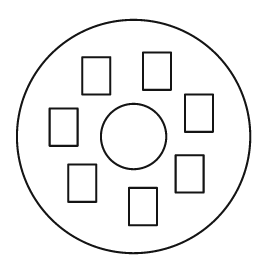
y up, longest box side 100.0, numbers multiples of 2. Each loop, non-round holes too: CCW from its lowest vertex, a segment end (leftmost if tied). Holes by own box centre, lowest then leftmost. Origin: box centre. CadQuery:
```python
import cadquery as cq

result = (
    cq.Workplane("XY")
    .moveTo(0.0, 0.0)
    .circle(50.0)
    .moveTo(-2.0, -38.0)
    .lineTo(10.0, -38.0)
    .lineTo(10.0, -22.0)
    .lineTo(-2.0, -22.0)
    .close()
    .moveTo(-28.0, -28.0)
    .lineTo(-16.0, -28.0)
    .lineTo(-16.0, -12.0)
    .lineTo(-28.0, -12.0)
    .close()
    .moveTo(18.0, -24.0)
    .lineTo(30.0, -24.0)
    .lineTo(30.0, -8.0)
    .lineTo(18.0, -8.0)
    .close()
    .moveTo(0.0, 0.0)
    .circle(14.0)
    .moveTo(-36.0, -4.0)
    .lineTo(-24.0, -4.0)
    .lineTo(-24.0, 12.0)
    .lineTo(-36.0, 12.0)
    .close()
    .moveTo(22.0, 2.0)
    .lineTo(34.0, 2.0)
    .lineTo(34.0, 18.0)
    .lineTo(22.0, 18.0)
    .close()
    .moveTo(-22.0, 18.0)
    .lineTo(-10.0, 18.0)
    .lineTo(-10.0, 34.0)
    .lineTo(-22.0, 34.0)
    .close()
    .moveTo(4.0, 20.0)
    .lineTo(16.0, 20.0)
    .lineTo(16.0, 36.0)
    .lineTo(4.0, 36.0)
    .close()
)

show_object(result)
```